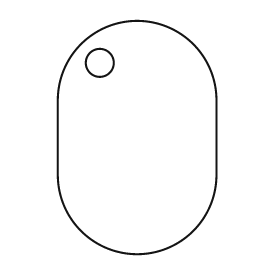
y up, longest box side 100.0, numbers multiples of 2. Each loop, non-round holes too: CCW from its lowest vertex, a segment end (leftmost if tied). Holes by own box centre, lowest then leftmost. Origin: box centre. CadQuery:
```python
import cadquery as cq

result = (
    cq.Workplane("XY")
    .moveTo(-34.0, -16.0)
    .threePointArc((0.0, -50.0), (34.0, -16.0))
    .lineTo(34.0, 16.0)
    .threePointArc((0.0, 50.0), (-34.0, 16.0))
    .close()
    .moveTo(-16.0, 32.0)
    .circle(6.0)
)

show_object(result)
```